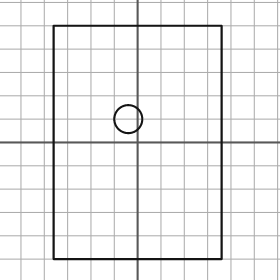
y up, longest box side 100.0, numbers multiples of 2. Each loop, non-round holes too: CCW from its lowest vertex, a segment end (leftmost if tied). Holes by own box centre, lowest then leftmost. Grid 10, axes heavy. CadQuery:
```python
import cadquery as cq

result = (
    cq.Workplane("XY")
    .moveTo(-36.0, -50.0)
    .lineTo(36.0, -50.0)
    .lineTo(36.0, 50.0)
    .lineTo(-36.0, 50.0)
    .close()
    .moveTo(-4.0, 10.0)
    .circle(6.0)
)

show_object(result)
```